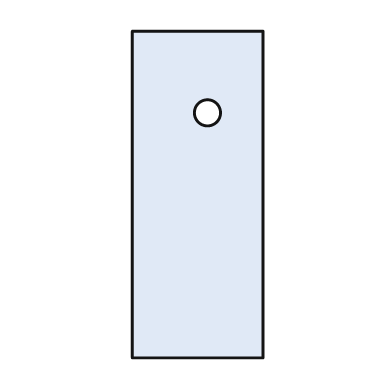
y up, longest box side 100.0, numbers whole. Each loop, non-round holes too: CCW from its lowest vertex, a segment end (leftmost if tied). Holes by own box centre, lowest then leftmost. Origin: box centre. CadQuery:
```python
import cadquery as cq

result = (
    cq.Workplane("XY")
    .moveTo(-20.0, -50.0)
    .lineTo(20.0, -50.0)
    .lineTo(20.0, 50.0)
    .lineTo(-20.0, 50.0)
    .close()
    .moveTo(3.0, 25.0)
    .circle(4.0)
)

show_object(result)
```